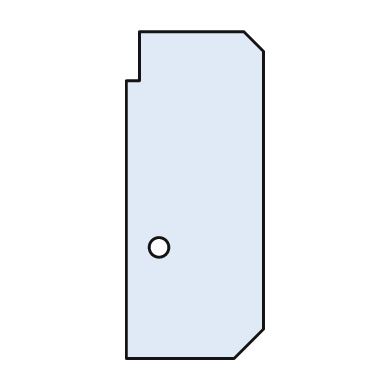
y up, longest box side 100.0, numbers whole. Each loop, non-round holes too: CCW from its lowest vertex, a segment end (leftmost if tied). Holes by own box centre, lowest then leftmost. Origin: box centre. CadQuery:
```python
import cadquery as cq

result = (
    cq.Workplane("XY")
    .moveTo(-21.0, -50.0)
    .lineTo(12.0, -50.0)
    .lineTo(21.0, -41.0)
    .lineTo(21.0, 44.0)
    .lineTo(15.0, 50.0)
    .lineTo(-17.0, 50.0)
    .lineTo(-17.0, 35.0)
    .lineTo(-21.0, 35.0)
    .close()
    .moveTo(-11.0, -16.0)
    .circle(3.0)
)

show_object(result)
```